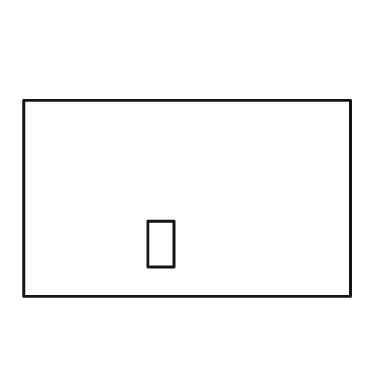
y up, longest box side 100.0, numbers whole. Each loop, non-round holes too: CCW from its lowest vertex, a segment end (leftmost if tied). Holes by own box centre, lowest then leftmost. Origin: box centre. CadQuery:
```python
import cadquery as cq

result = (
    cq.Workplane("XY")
    .moveTo(-50.0, -30.0)
    .lineTo(50.0, -30.0)
    .lineTo(50.0, 30.0)
    .lineTo(-50.0, 30.0)
    .close()
    .moveTo(-12.0, -21.0)
    .lineTo(-4.0, -21.0)
    .lineTo(-4.0, -7.0)
    .lineTo(-12.0, -7.0)
    .close()
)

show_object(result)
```